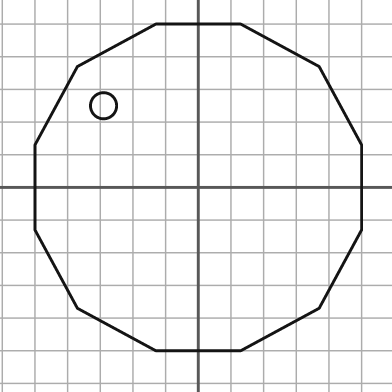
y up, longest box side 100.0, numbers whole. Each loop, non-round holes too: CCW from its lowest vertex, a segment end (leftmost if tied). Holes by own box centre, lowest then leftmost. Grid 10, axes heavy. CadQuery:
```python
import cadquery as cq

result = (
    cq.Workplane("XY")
    .moveTo(-13.0, -50.0)
    .lineTo(13.0, -50.0)
    .lineTo(37.0, -37.0)
    .lineTo(50.0, -13.0)
    .lineTo(50.0, 13.0)
    .lineTo(37.0, 37.0)
    .lineTo(13.0, 50.0)
    .lineTo(-13.0, 50.0)
    .lineTo(-37.0, 37.0)
    .lineTo(-50.0, 13.0)
    .lineTo(-50.0, -13.0)
    .lineTo(-37.0, -37.0)
    .close()
    .moveTo(-29.0, 25.0)
    .circle(4.0)
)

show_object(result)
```